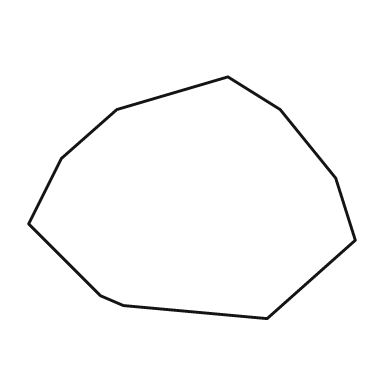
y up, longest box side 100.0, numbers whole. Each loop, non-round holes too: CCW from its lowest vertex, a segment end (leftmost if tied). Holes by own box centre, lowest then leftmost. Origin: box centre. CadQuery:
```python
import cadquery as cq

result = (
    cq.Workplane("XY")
    .moveTo(23.0, -37.0)
    .lineTo(50.0, -13.0)
    .lineTo(44.0, 6.0)
    .lineTo(27.0, 27.0)
    .lineTo(11.0, 37.0)
    .lineTo(-23.0, 27.0)
    .lineTo(-40.0, 12.0)
    .lineTo(-50.0, -8.0)
    .lineTo(-28.0, -30.0)
    .lineTo(-21.0, -33.0)
    .close()
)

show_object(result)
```